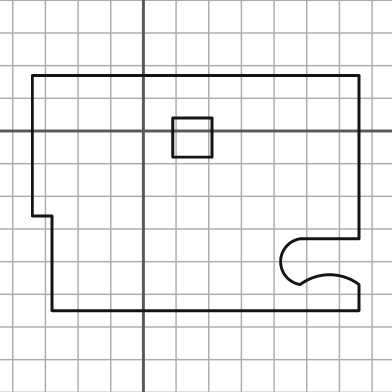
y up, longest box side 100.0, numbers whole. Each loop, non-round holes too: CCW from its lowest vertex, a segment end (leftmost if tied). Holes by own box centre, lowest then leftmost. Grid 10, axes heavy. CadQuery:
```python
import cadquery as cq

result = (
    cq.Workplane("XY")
    .moveTo(-28.0, -55.0)
    .lineTo(66.0, -55.0)
    .lineTo(66.0, -47.0)
    .threePointArc((57.0, -44.0), (48.0, -47.0))
    .threePointArc((42.0, -40.0), (48.0, -33.0))
    .lineTo(66.0, -33.0)
    .lineTo(66.0, 17.0)
    .lineTo(-34.0, 17.0)
    .lineTo(-34.0, -26.0)
    .lineTo(-28.0, -26.0)
    .close()
    .moveTo(9.0, -8.0)
    .lineTo(21.0, -8.0)
    .lineTo(21.0, 4.0)
    .lineTo(9.0, 4.0)
    .close()
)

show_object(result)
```